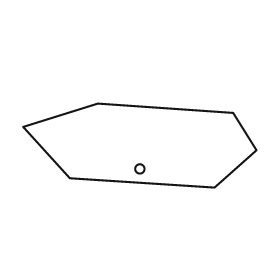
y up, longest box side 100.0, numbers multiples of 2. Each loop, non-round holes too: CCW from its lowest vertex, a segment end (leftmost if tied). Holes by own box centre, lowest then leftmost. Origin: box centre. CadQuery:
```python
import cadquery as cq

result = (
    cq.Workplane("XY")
    .moveTo(32.0, -18.0)
    .lineTo(50.0, -2.0)
    .lineTo(40.0, 14.0)
    .lineTo(-18.0, 18.0)
    .lineTo(-50.0, 8.0)
    .lineTo(-30.0, -14.0)
    .close()
    .moveTo(0.0, -10.0)
    .circle(2.0)
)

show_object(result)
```